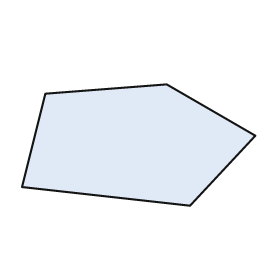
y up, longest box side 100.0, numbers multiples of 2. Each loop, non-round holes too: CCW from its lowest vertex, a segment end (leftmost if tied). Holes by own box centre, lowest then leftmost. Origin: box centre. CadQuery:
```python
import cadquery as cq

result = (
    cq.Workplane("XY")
    .moveTo(22.0, -26.0)
    .lineTo(50.0, 4.0)
    .lineTo(12.0, 26.0)
    .lineTo(-40.0, 22.0)
    .lineTo(-50.0, -18.0)
    .close()
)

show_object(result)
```